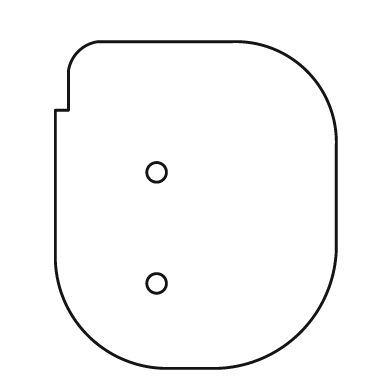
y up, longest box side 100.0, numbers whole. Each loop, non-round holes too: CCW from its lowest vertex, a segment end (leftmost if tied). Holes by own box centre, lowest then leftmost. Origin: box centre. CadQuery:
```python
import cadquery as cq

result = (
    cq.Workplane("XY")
    .moveTo(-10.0, -50.0)
    .lineTo(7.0, -50.0)
    .threePointArc((32.0, -39.0), (43.0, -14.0))
    .lineTo(43.0, 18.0)
    .threePointArc((34.0, 41.0), (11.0, 50.0))
    .lineTo(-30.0, 50.0)
    .threePointArc((-36.0, 47.0), (-39.0, 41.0))
    .lineTo(-39.0, 29.0)
    .lineTo(-43.0, 29.0)
    .lineTo(-43.0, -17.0)
    .threePointArc((-33.0, -40.0), (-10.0, -50.0))
    .close()
    .moveTo(-12.0, -24.0)
    .circle(3.0)
    .moveTo(-12.0, 10.0)
    .circle(3.0)
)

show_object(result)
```